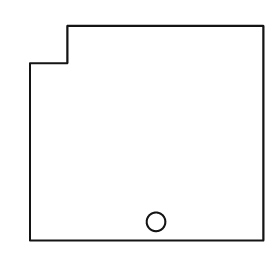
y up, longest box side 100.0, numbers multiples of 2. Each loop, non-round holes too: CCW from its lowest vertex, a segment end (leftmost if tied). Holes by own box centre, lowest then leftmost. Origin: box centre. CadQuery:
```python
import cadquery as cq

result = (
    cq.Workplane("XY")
    .moveTo(-50.0, -46.0)
    .lineTo(50.0, -46.0)
    .lineTo(50.0, 46.0)
    .lineTo(-34.0, 46.0)
    .lineTo(-34.0, 30.0)
    .lineTo(-50.0, 30.0)
    .close()
    .moveTo(4.0, -38.0)
    .circle(4.0)
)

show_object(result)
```